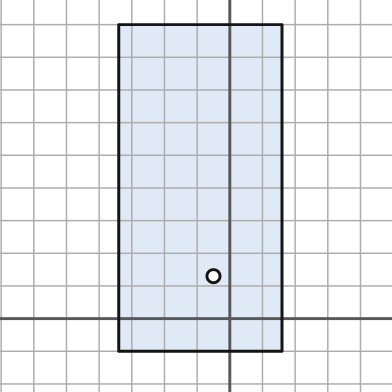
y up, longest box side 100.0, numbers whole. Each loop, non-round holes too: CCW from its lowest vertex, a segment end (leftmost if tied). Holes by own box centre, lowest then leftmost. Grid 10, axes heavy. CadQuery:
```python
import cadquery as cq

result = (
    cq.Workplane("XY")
    .moveTo(-34.0, -10.0)
    .lineTo(16.0, -10.0)
    .lineTo(16.0, 90.0)
    .lineTo(-34.0, 90.0)
    .close()
    .moveTo(-5.0, 13.0)
    .circle(2.0)
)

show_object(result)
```